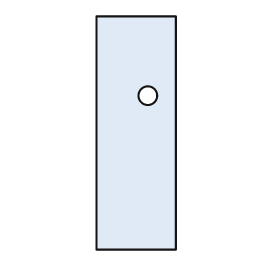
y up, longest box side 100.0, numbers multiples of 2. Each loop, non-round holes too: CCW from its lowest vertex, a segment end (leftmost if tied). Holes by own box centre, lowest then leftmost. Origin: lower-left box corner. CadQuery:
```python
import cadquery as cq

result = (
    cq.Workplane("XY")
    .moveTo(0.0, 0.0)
    .lineTo(34.0, 0.0)
    .lineTo(34.0, 100.0)
    .lineTo(0.0, 100.0)
    .close()
    .moveTo(22.0, 66.0)
    .circle(4.0)
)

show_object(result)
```